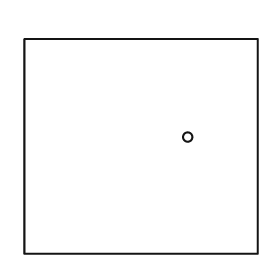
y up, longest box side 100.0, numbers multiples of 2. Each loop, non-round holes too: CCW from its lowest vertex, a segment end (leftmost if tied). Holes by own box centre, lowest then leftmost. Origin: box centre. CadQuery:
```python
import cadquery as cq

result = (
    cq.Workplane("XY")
    .moveTo(-50.0, -46.0)
    .lineTo(50.0, -46.0)
    .lineTo(50.0, 46.0)
    .lineTo(-50.0, 46.0)
    .close()
    .moveTo(20.0, 4.0)
    .circle(2.0)
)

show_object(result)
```